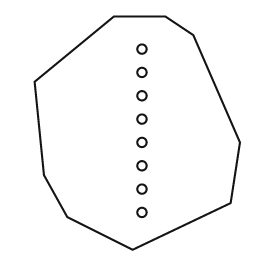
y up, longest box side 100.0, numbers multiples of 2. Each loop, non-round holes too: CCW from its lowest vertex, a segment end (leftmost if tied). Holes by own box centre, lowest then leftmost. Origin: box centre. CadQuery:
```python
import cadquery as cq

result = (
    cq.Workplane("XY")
    .moveTo(-2.0, -50.0)
    .lineTo(40.0, -30.0)
    .lineTo(44.0, -4.0)
    .lineTo(24.0, 42.0)
    .lineTo(12.0, 50.0)
    .lineTo(-10.0, 50.0)
    .lineTo(-44.0, 22.0)
    .lineTo(-40.0, -18.0)
    .lineTo(-30.0, -36.0)
    .close()
    .moveTo(2.0, -34.0)
    .circle(2.0)
    .moveTo(2.0, -24.0)
    .circle(2.0)
    .moveTo(2.0, -14.0)
    .circle(2.0)
    .moveTo(2.0, -4.0)
    .circle(2.0)
    .moveTo(2.0, 6.0)
    .circle(2.0)
    .moveTo(2.0, 16.0)
    .circle(2.0)
    .moveTo(2.0, 26.0)
    .circle(2.0)
    .moveTo(2.0, 36.0)
    .circle(2.0)
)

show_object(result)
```